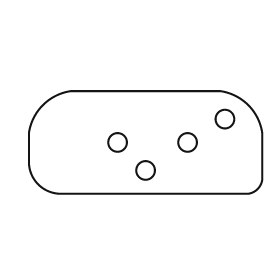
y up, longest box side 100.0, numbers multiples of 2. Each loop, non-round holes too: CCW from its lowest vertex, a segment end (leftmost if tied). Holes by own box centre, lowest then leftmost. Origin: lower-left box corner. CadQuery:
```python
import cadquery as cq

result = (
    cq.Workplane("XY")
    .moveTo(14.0, 0.0)
    .lineTo(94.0, 0.0)
    .threePointArc((98.0, 2.0), (100.0, 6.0))
    .lineTo(100.0, 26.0)
    .threePointArc((94.0, 38.0), (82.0, 44.0))
    .lineTo(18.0, 44.0)
    .threePointArc((6.0, 38.0), (0.0, 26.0))
    .lineTo(0.0, 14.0)
    .threePointArc((4.0, 4.0), (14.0, 0.0))
    .close()
    .moveTo(50.0, 10.0)
    .circle(4.0)
    .moveTo(38.0, 22.0)
    .circle(4.0)
    .moveTo(68.0, 22.0)
    .circle(4.0)
    .moveTo(84.0, 32.0)
    .circle(4.0)
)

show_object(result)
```